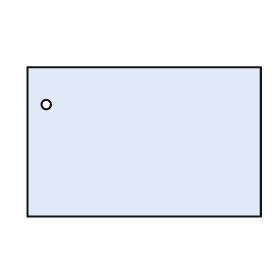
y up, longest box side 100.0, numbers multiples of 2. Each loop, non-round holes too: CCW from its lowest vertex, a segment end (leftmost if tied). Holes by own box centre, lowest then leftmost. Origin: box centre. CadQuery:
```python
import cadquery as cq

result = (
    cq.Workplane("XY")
    .moveTo(-50.0, -32.0)
    .lineTo(50.0, -32.0)
    .lineTo(50.0, 32.0)
    .lineTo(-50.0, 32.0)
    .close()
    .moveTo(-42.0, 16.0)
    .circle(2.0)
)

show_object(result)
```